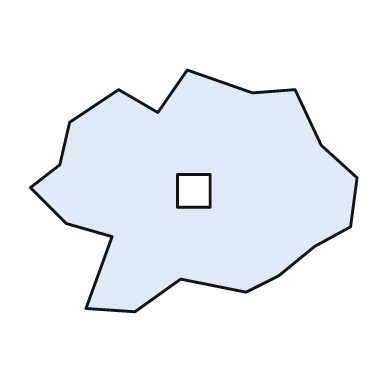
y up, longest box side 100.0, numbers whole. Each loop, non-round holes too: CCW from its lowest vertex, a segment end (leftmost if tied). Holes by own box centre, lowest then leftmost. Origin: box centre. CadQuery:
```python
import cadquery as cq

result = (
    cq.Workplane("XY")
    .moveTo(-18.0, -37.0)
    .lineTo(-4.0, -27.0)
    .lineTo(16.0, -31.0)
    .lineTo(26.0, -26.0)
    .lineTo(37.0, -17.0)
    .lineTo(48.0, -11.0)
    .lineTo(50.0, 4.0)
    .lineTo(39.0, 14.0)
    .lineTo(31.0, 31.0)
    .lineTo(18.0, 30.0)
    .lineTo(-2.0, 37.0)
    .lineTo(-11.0, 24.0)
    .lineTo(-23.0, 31.0)
    .lineTo(-38.0, 21.0)
    .lineTo(-41.0, 8.0)
    .lineTo(-50.0, 1.0)
    .lineTo(-39.0, -10.0)
    .lineTo(-25.0, -14.0)
    .lineTo(-33.0, -36.0)
    .close()
    .moveTo(-5.0, -5.0)
    .lineTo(5.0, -5.0)
    .lineTo(5.0, 5.0)
    .lineTo(-5.0, 5.0)
    .close()
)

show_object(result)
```